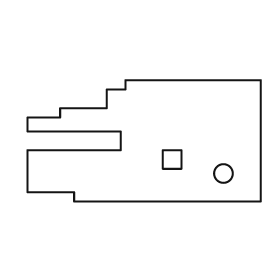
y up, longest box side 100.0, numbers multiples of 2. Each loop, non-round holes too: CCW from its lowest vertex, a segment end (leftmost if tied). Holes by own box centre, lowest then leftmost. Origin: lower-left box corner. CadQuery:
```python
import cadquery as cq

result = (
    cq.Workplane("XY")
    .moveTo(20.0, 0.0)
    .lineTo(100.0, 0.0)
    .lineTo(100.0, 52.0)
    .lineTo(42.0, 52.0)
    .lineTo(42.0, 48.0)
    .lineTo(34.0, 48.0)
    .lineTo(34.0, 40.0)
    .lineTo(14.0, 40.0)
    .lineTo(14.0, 36.0)
    .lineTo(0.0, 36.0)
    .lineTo(0.0, 30.0)
    .lineTo(40.0, 30.0)
    .lineTo(40.0, 22.0)
    .lineTo(0.0, 22.0)
    .lineTo(0.0, 4.0)
    .lineTo(20.0, 4.0)
    .close()
    .moveTo(84.0, 12.0)
    .circle(4.0)
    .moveTo(58.0, 14.0)
    .lineTo(66.0, 14.0)
    .lineTo(66.0, 22.0)
    .lineTo(58.0, 22.0)
    .close()
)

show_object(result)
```